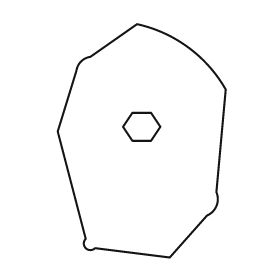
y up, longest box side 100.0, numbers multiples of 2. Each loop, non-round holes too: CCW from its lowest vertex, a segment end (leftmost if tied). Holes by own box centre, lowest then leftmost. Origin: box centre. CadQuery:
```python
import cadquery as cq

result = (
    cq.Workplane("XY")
    .moveTo(12.0, -50.0)
    .lineTo(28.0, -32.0)
    .threePointArc((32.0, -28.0), (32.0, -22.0))
    .lineTo(36.0, 22.0)
    .threePointArc((20.0, 40.0), (-2.0, 50.0))
    .lineTo(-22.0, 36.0)
    .threePointArc((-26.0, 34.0), (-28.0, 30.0))
    .lineTo(-36.0, 4.0)
    .lineTo(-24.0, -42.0)
    .threePointArc((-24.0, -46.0), (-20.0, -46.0))
    .close()
    .moveTo(-4.0, 0.0)
    .lineTo(4.0, 0.0)
    .lineTo(8.0, 6.0)
    .lineTo(4.0, 12.0)
    .lineTo(-4.0, 12.0)
    .lineTo(-8.0, 6.0)
    .close()
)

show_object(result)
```